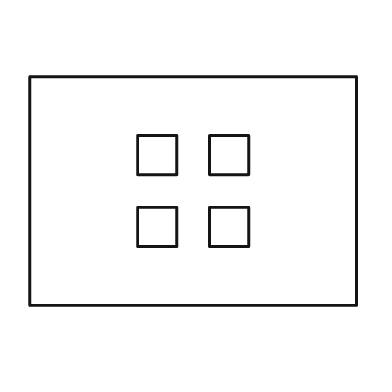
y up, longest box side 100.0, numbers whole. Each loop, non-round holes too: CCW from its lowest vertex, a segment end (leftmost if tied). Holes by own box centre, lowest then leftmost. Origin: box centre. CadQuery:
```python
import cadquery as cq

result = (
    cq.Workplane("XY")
    .moveTo(-50.0, -35.0)
    .lineTo(50.0, -35.0)
    .lineTo(50.0, 35.0)
    .lineTo(-50.0, 35.0)
    .close()
    .moveTo(-17.0, -17.0)
    .lineTo(-5.0, -17.0)
    .lineTo(-5.0, -5.0)
    .lineTo(-17.0, -5.0)
    .close()
    .moveTo(5.0, -17.0)
    .lineTo(17.0, -17.0)
    .lineTo(17.0, -5.0)
    .lineTo(5.0, -5.0)
    .close()
    .moveTo(-17.0, 5.0)
    .lineTo(-5.0, 5.0)
    .lineTo(-5.0, 17.0)
    .lineTo(-17.0, 17.0)
    .close()
    .moveTo(5.0, 5.0)
    .lineTo(17.0, 5.0)
    .lineTo(17.0, 17.0)
    .lineTo(5.0, 17.0)
    .close()
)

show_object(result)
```